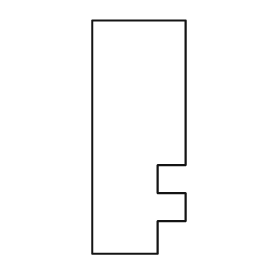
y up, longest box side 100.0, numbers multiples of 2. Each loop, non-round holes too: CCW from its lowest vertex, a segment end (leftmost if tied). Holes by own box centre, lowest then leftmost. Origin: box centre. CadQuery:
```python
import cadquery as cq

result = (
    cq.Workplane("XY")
    .moveTo(-20.0, -50.0)
    .lineTo(8.0, -50.0)
    .lineTo(8.0, -36.0)
    .lineTo(20.0, -36.0)
    .lineTo(20.0, -24.0)
    .lineTo(8.0, -24.0)
    .lineTo(8.0, -12.0)
    .lineTo(20.0, -12.0)
    .lineTo(20.0, 50.0)
    .lineTo(-20.0, 50.0)
    .close()
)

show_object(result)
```